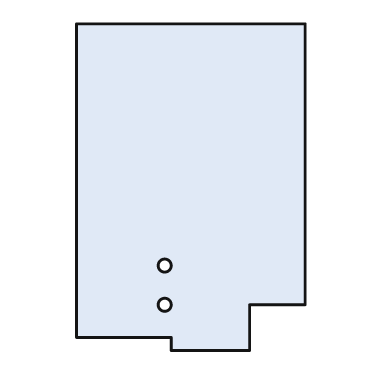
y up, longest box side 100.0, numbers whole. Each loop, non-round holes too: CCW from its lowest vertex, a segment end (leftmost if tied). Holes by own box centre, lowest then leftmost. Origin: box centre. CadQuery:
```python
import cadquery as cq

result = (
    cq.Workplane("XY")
    .moveTo(-6.0, -50.0)
    .lineTo(18.0, -50.0)
    .lineTo(18.0, -36.0)
    .lineTo(35.0, -36.0)
    .lineTo(35.0, 50.0)
    .lineTo(-35.0, 50.0)
    .lineTo(-35.0, -46.0)
    .lineTo(-6.0, -46.0)
    .close()
    .moveTo(-8.0, -36.0)
    .circle(2.0)
    .moveTo(-8.0, -24.0)
    .circle(2.0)
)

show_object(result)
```